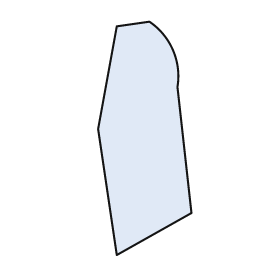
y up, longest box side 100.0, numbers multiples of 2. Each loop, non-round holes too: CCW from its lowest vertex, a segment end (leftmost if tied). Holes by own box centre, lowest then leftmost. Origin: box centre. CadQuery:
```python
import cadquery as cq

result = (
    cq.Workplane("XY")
    .moveTo(-12.0, -50.0)
    .lineTo(20.0, -32.0)
    .lineTo(14.0, 22.0)
    .threePointArc((12.0, 38.0), (2.0, 50.0))
    .lineTo(-12.0, 48.0)
    .lineTo(-20.0, 4.0)
    .close()
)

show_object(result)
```